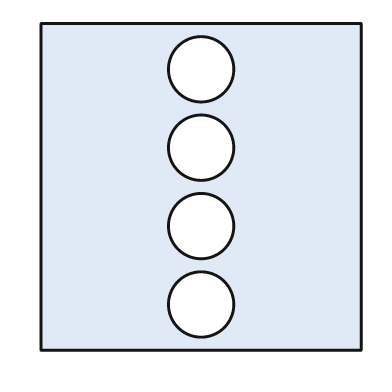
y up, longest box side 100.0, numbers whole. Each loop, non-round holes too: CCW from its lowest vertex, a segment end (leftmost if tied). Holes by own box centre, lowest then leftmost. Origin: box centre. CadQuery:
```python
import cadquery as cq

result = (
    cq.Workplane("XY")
    .moveTo(-49.0, -50.0)
    .lineTo(49.0, -50.0)
    .lineTo(49.0, 50.0)
    .lineTo(-49.0, 50.0)
    .close()
    .moveTo(0.0, -36.0)
    .circle(10.0)
    .moveTo(0.0, -12.0)
    .circle(10.0)
    .moveTo(0.0, 12.0)
    .circle(10.0)
    .moveTo(0.0, 36.0)
    .circle(10.0)
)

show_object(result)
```